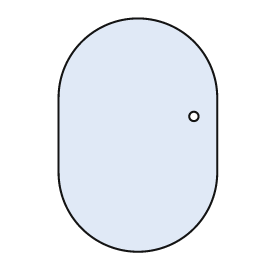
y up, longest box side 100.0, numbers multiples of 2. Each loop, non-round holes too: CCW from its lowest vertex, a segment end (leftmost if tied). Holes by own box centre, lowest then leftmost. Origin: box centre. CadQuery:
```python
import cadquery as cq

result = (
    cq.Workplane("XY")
    .moveTo(-34.0, -16.0)
    .threePointArc((0.0, -50.0), (34.0, -16.0))
    .lineTo(34.0, 16.0)
    .threePointArc((0.0, 50.0), (-34.0, 16.0))
    .close()
    .moveTo(24.0, 8.0)
    .circle(2.0)
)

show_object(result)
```